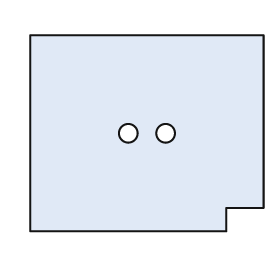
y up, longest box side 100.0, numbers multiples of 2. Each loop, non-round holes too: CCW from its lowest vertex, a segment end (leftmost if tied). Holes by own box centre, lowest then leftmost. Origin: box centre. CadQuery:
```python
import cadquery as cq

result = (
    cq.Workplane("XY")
    .moveTo(-50.0, -42.0)
    .lineTo(34.0, -42.0)
    .lineTo(34.0, -32.0)
    .lineTo(50.0, -32.0)
    .lineTo(50.0, 42.0)
    .lineTo(-50.0, 42.0)
    .close()
    .moveTo(-8.0, 0.0)
    .circle(4.0)
    .moveTo(8.0, 0.0)
    .circle(4.0)
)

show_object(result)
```